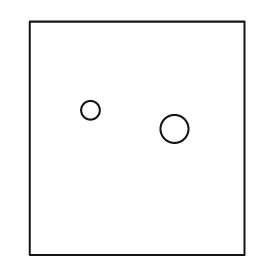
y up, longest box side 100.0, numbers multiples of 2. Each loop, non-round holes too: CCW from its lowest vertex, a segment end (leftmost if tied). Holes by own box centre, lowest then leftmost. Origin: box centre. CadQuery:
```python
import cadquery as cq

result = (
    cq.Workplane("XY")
    .moveTo(-46.0, -50.0)
    .lineTo(46.0, -50.0)
    .lineTo(46.0, 50.0)
    .lineTo(-46.0, 50.0)
    .close()
    .moveTo(16.0, 4.0)
    .circle(6.0)
    .moveTo(-20.0, 12.0)
    .circle(4.0)
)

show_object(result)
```